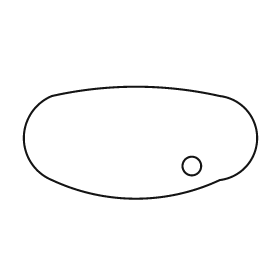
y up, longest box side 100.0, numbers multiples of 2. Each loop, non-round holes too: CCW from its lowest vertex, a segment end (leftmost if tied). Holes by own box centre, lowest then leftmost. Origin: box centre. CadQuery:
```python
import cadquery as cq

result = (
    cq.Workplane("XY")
    .moveTo(-38.0, -16.0)
    .threePointArc((-2.0, -24.0), (34.0, -16.0))
    .threePointArc((50.0, 2.0), (34.0, 20.0))
    .threePointArc((-2.0, 24.0), (-38.0, 20.0))
    .threePointArc((-50.0, 2.0), (-38.0, -16.0))
    .close()
    .moveTo(22.0, -10.0)
    .circle(4.0)
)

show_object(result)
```